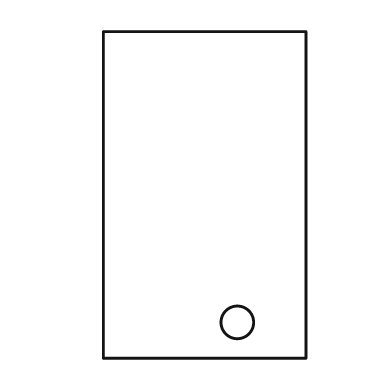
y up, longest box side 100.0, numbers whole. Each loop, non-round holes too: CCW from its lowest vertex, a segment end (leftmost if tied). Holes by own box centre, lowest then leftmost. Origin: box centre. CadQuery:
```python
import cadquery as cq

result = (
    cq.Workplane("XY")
    .moveTo(-31.0, -50.0)
    .lineTo(31.0, -50.0)
    .lineTo(31.0, 50.0)
    .lineTo(-31.0, 50.0)
    .close()
    .moveTo(10.0, -39.0)
    .circle(5.0)
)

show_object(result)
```